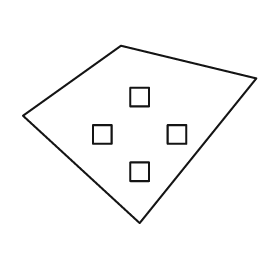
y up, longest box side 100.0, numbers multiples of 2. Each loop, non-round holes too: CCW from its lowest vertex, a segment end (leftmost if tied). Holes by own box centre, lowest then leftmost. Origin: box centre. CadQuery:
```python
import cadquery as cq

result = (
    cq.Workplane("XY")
    .moveTo(0.0, -38.0)
    .lineTo(50.0, 24.0)
    .lineTo(-8.0, 38.0)
    .lineTo(-50.0, 8.0)
    .close()
    .moveTo(-4.0, -20.0)
    .lineTo(4.0, -20.0)
    .lineTo(4.0, -12.0)
    .lineTo(-4.0, -12.0)
    .close()
    .moveTo(-20.0, -4.0)
    .lineTo(-12.0, -4.0)
    .lineTo(-12.0, 4.0)
    .lineTo(-20.0, 4.0)
    .close()
    .moveTo(12.0, -4.0)
    .lineTo(20.0, -4.0)
    .lineTo(20.0, 4.0)
    .lineTo(12.0, 4.0)
    .close()
    .moveTo(-4.0, 12.0)
    .lineTo(4.0, 12.0)
    .lineTo(4.0, 20.0)
    .lineTo(-4.0, 20.0)
    .close()
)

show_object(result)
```